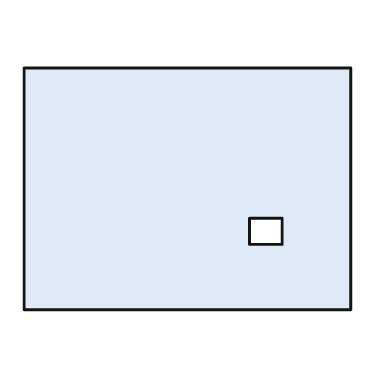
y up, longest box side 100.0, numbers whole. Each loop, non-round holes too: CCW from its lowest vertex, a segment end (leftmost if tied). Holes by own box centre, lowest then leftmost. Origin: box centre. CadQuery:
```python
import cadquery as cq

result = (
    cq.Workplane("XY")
    .moveTo(-50.0, -37.0)
    .lineTo(50.0, -37.0)
    .lineTo(50.0, 37.0)
    .lineTo(-50.0, 37.0)
    .close()
    .moveTo(19.0, -17.0)
    .lineTo(29.0, -17.0)
    .lineTo(29.0, -9.0)
    .lineTo(19.0, -9.0)
    .close()
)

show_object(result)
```